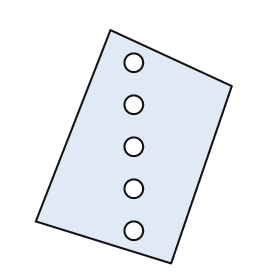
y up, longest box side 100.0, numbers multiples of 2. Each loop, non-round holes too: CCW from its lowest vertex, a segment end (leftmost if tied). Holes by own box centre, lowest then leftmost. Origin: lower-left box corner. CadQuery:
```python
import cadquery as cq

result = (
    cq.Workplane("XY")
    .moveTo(58.0, 0.0)
    .lineTo(84.0, 76.0)
    .lineTo(32.0, 100.0)
    .lineTo(0.0, 18.0)
    .close()
    .moveTo(42.0, 14.0)
    .circle(4.0)
    .moveTo(42.0, 32.0)
    .circle(4.0)
    .moveTo(42.0, 50.0)
    .circle(4.0)
    .moveTo(42.0, 68.0)
    .circle(4.0)
    .moveTo(42.0, 86.0)
    .circle(4.0)
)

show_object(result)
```